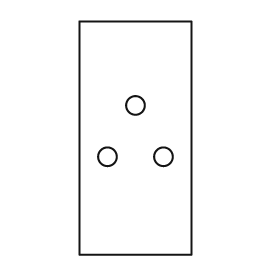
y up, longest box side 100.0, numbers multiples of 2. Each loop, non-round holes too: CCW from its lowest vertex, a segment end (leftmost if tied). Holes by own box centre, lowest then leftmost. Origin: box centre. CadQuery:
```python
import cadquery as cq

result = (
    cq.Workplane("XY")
    .moveTo(-24.0, -50.0)
    .lineTo(24.0, -50.0)
    .lineTo(24.0, 50.0)
    .lineTo(-24.0, 50.0)
    .close()
    .moveTo(-12.0, -8.0)
    .circle(4.0)
    .moveTo(12.0, -8.0)
    .circle(4.0)
    .moveTo(0.0, 14.0)
    .circle(4.0)
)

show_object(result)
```